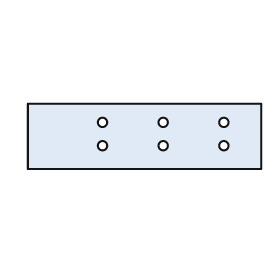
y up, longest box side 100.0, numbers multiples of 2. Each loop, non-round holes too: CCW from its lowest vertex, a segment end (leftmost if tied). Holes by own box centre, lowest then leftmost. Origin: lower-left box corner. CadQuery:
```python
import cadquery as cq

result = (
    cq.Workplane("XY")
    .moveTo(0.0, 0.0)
    .lineTo(100.0, 0.0)
    .lineTo(100.0, 28.0)
    .lineTo(0.0, 28.0)
    .close()
    .moveTo(32.0, 10.0)
    .circle(2.0)
    .moveTo(58.0, 10.0)
    .circle(2.0)
    .moveTo(84.0, 10.0)
    .circle(2.0)
    .moveTo(32.0, 20.0)
    .circle(2.0)
    .moveTo(58.0, 20.0)
    .circle(2.0)
    .moveTo(84.0, 20.0)
    .circle(2.0)
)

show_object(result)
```